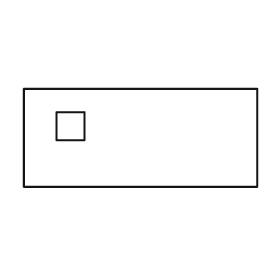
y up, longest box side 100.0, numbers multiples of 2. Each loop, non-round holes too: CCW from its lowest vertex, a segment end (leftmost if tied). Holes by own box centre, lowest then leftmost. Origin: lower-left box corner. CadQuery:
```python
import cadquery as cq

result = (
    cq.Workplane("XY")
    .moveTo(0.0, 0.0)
    .lineTo(100.0, 0.0)
    .lineTo(100.0, 42.0)
    .lineTo(0.0, 42.0)
    .close()
    .moveTo(14.0, 20.0)
    .lineTo(26.0, 20.0)
    .lineTo(26.0, 32.0)
    .lineTo(14.0, 32.0)
    .close()
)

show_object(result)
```